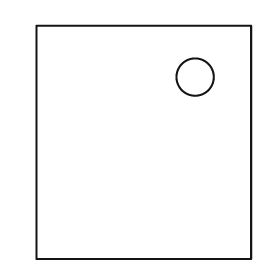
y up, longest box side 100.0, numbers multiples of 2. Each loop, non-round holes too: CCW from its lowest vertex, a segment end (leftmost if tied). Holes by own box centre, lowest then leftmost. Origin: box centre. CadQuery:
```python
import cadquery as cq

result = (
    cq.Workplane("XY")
    .moveTo(-46.0, -50.0)
    .lineTo(46.0, -50.0)
    .lineTo(46.0, 50.0)
    .lineTo(-46.0, 50.0)
    .close()
    .moveTo(22.0, 28.0)
    .circle(8.0)
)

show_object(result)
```